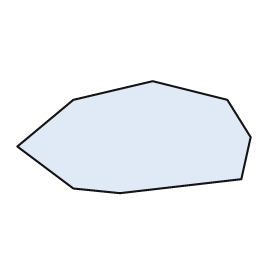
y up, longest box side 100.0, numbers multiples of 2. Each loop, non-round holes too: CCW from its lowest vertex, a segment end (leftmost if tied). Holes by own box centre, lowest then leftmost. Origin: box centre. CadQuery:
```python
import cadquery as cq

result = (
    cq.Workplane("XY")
    .moveTo(-6.0, -24.0)
    .lineTo(46.0, -18.0)
    .lineTo(50.0, 0.0)
    .lineTo(40.0, 16.0)
    .lineTo(8.0, 24.0)
    .lineTo(-26.0, 16.0)
    .lineTo(-50.0, -4.0)
    .lineTo(-26.0, -22.0)
    .close()
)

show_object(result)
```